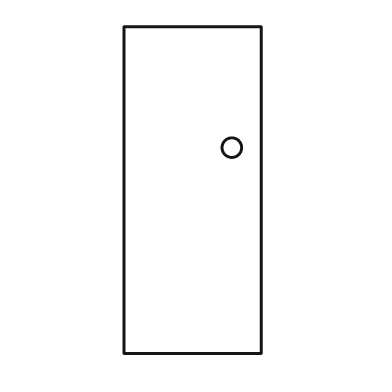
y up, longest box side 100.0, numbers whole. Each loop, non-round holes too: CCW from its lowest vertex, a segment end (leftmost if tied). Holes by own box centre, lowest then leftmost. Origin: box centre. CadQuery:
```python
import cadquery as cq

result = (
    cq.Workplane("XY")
    .moveTo(-21.0, -50.0)
    .lineTo(21.0, -50.0)
    .lineTo(21.0, 50.0)
    .lineTo(-21.0, 50.0)
    .close()
    .moveTo(12.0, 13.0)
    .circle(3.0)
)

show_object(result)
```